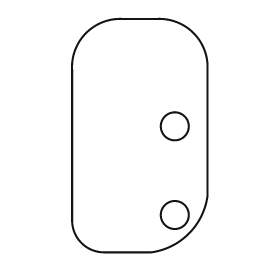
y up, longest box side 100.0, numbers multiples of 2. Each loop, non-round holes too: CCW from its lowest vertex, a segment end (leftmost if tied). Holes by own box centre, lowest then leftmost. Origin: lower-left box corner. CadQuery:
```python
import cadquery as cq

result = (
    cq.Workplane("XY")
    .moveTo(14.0, 0.0)
    .lineTo(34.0, 0.0)
    .threePointArc((50.0, 8.0), (58.0, 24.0))
    .lineTo(58.0, 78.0)
    .threePointArc((52.0, 94.0), (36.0, 100.0))
    .lineTo(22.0, 100.0)
    .threePointArc((6.0, 94.0), (0.0, 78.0))
    .lineTo(0.0, 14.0)
    .threePointArc((4.0, 4.0), (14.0, 0.0))
    .close()
    .moveTo(44.0, 16.0)
    .circle(6.0)
    .moveTo(44.0, 54.0)
    .circle(6.0)
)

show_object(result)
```